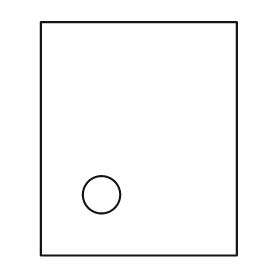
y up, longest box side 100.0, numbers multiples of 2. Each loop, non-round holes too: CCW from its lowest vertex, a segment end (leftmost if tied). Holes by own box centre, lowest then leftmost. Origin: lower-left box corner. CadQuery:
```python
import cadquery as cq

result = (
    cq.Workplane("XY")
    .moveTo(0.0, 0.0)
    .lineTo(84.0, 0.0)
    .lineTo(84.0, 100.0)
    .lineTo(0.0, 100.0)
    .close()
    .moveTo(26.0, 26.0)
    .circle(8.0)
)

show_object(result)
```